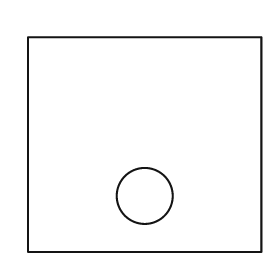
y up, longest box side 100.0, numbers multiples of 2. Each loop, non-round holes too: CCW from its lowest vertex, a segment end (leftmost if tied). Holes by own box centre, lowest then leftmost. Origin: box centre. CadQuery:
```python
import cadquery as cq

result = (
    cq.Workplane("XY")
    .moveTo(-50.0, -46.0)
    .lineTo(50.0, -46.0)
    .lineTo(50.0, 46.0)
    .lineTo(-50.0, 46.0)
    .close()
    .moveTo(0.0, -22.0)
    .circle(12.0)
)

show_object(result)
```